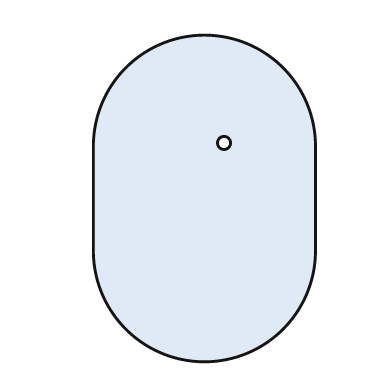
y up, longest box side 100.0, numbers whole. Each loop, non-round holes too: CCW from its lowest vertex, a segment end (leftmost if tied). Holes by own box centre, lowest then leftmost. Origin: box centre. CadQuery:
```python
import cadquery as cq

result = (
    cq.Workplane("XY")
    .moveTo(-34.0, -16.0)
    .threePointArc((0.0, -50.0), (34.0, -16.0))
    .lineTo(34.0, 16.0)
    .threePointArc((0.0, 50.0), (-34.0, 16.0))
    .close()
    .moveTo(6.0, 17.0)
    .circle(2.0)
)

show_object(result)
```